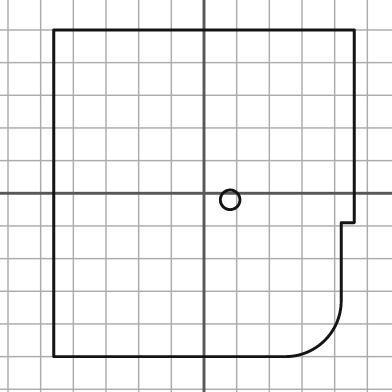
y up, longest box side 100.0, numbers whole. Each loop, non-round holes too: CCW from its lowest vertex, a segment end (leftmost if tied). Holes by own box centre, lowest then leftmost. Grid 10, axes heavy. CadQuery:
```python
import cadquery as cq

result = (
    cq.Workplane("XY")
    .moveTo(-46.0, -50.0)
    .lineTo(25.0, -50.0)
    .threePointArc((37.0, -45.0), (42.0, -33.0))
    .lineTo(42.0, -9.0)
    .lineTo(46.0, -9.0)
    .lineTo(46.0, 50.0)
    .lineTo(-46.0, 50.0)
    .close()
    .moveTo(8.0, -2.0)
    .circle(3.0)
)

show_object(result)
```